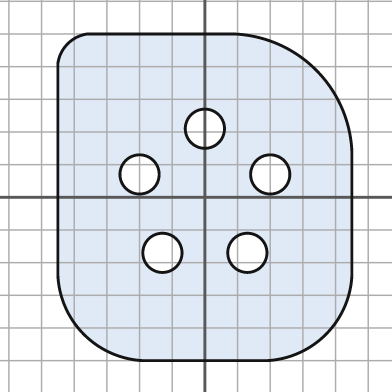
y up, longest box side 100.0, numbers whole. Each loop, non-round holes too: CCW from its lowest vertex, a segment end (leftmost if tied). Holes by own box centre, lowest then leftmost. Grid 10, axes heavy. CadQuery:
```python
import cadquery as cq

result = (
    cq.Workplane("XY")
    .moveTo(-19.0, -50.0)
    .lineTo(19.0, -50.0)
    .threePointArc((37.0, -42.0), (45.0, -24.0))
    .lineTo(45.0, 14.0)
    .threePointArc((34.0, 39.0), (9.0, 50.0))
    .lineTo(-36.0, 50.0)
    .threePointArc((-42.0, 47.0), (-45.0, 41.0))
    .lineTo(-45.0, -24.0)
    .threePointArc((-37.0, -42.0), (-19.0, -50.0))
    .close()
    .moveTo(-13.0, -17.0)
    .circle(6.0)
    .moveTo(13.0, -17.0)
    .circle(6.0)
    .moveTo(-20.0, 7.0)
    .circle(6.0)
    .moveTo(20.0, 7.0)
    .circle(6.0)
    .moveTo(0.0, 21.0)
    .circle(6.0)
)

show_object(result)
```